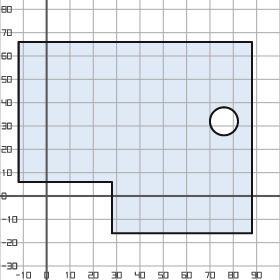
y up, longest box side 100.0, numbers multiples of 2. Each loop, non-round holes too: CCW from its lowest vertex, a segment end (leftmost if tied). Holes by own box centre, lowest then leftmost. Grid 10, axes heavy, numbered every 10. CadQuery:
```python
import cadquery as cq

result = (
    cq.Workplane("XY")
    .moveTo(28.0, -16.0)
    .lineTo(88.0, -16.0)
    .lineTo(88.0, 66.0)
    .lineTo(-12.0, 66.0)
    .lineTo(-12.0, 6.0)
    .lineTo(28.0, 6.0)
    .close()
    .moveTo(76.0, 32.0)
    .circle(6.0)
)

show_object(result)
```